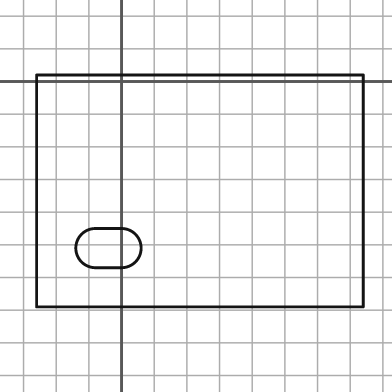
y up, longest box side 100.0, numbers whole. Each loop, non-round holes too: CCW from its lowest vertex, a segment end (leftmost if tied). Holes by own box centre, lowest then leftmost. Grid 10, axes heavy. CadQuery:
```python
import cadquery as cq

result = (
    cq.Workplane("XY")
    .moveTo(-26.0, -69.0)
    .lineTo(74.0, -69.0)
    .lineTo(74.0, 2.0)
    .lineTo(-26.0, 2.0)
    .close()
    .moveTo(-8.0, -57.0)
    .lineTo(0.0, -57.0)
    .threePointArc((6.0, -51.0), (0.0, -45.0))
    .lineTo(-8.0, -45.0)
    .threePointArc((-14.0, -51.0), (-8.0, -57.0))
    .close()
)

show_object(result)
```